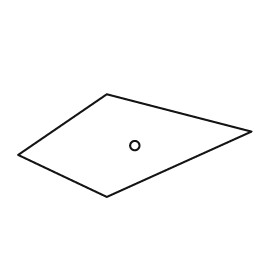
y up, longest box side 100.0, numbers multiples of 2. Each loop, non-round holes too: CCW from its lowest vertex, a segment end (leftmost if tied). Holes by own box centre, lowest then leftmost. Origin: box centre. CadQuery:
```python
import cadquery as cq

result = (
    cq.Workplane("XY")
    .moveTo(-12.0, -22.0)
    .lineTo(50.0, 6.0)
    .lineTo(-12.0, 22.0)
    .lineTo(-50.0, -4.0)
    .close()
    .moveTo(0.0, 0.0)
    .circle(2.0)
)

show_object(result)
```